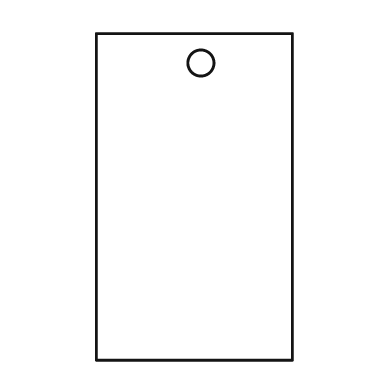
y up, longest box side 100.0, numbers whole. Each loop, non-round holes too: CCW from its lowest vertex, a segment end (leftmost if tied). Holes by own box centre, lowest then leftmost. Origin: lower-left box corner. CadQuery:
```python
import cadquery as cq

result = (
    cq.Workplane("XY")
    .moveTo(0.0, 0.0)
    .lineTo(60.0, 0.0)
    .lineTo(60.0, 100.0)
    .lineTo(0.0, 100.0)
    .close()
    .moveTo(32.0, 91.0)
    .circle(4.0)
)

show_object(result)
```